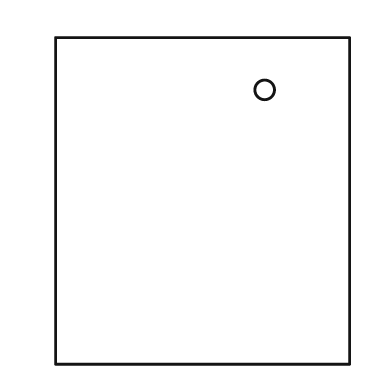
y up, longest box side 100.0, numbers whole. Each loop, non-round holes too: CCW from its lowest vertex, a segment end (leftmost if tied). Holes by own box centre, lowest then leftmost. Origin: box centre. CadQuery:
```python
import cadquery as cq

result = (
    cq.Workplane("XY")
    .moveTo(-45.0, -50.0)
    .lineTo(45.0, -50.0)
    .lineTo(45.0, 50.0)
    .lineTo(-45.0, 50.0)
    .close()
    .moveTo(19.0, 34.0)
    .circle(3.0)
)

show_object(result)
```